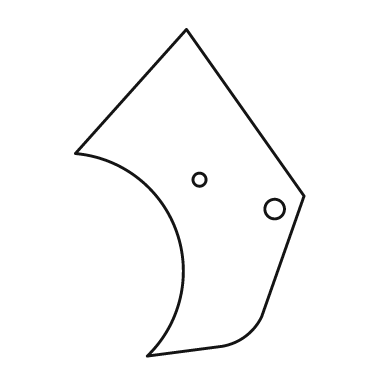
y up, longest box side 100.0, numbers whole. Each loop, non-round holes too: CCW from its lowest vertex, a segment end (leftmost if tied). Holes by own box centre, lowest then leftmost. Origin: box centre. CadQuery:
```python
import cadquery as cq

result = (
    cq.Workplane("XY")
    .moveTo(-13.0, -50.0)
    .lineTo(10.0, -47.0)
    .threePointArc((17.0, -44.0), (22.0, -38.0))
    .lineTo(35.0, -1.0)
    .lineTo(-1.0, 50.0)
    .lineTo(-35.0, 12.0)
    .threePointArc((-4.0, -12.0), (-13.0, -50.0))
    .close()
    .moveTo(26.0, -5.0)
    .circle(3.0)
    .moveTo(3.0, 4.0)
    .circle(2.0)
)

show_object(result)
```